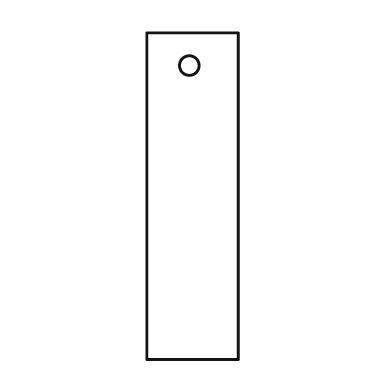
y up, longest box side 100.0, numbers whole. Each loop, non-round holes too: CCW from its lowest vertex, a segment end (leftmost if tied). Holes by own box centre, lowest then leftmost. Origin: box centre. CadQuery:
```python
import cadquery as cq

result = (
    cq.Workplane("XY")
    .moveTo(-14.0, -50.0)
    .lineTo(14.0, -50.0)
    .lineTo(14.0, 50.0)
    .lineTo(-14.0, 50.0)
    .close()
    .moveTo(-1.0, 40.0)
    .circle(3.0)
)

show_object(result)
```